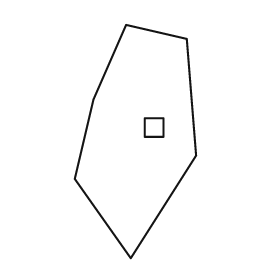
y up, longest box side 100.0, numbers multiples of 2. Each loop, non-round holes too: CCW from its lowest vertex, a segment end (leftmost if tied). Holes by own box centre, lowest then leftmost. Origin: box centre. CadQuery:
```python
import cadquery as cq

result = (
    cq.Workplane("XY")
    .moveTo(-2.0, -50.0)
    .lineTo(26.0, -6.0)
    .lineTo(22.0, 44.0)
    .lineTo(-4.0, 50.0)
    .lineTo(-18.0, 18.0)
    .lineTo(-26.0, -16.0)
    .close()
    .moveTo(4.0, 2.0)
    .lineTo(12.0, 2.0)
    .lineTo(12.0, 10.0)
    .lineTo(4.0, 10.0)
    .close()
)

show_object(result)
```